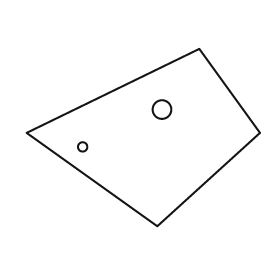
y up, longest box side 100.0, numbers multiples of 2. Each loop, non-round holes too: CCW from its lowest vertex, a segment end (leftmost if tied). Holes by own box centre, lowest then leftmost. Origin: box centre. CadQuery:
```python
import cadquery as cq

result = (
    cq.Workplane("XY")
    .moveTo(6.0, -38.0)
    .lineTo(50.0, 2.0)
    .lineTo(24.0, 38.0)
    .lineTo(-50.0, 2.0)
    .close()
    .moveTo(-26.0, -4.0)
    .circle(2.0)
    .moveTo(8.0, 12.0)
    .circle(4.0)
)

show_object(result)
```